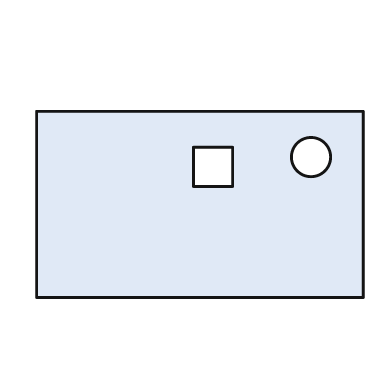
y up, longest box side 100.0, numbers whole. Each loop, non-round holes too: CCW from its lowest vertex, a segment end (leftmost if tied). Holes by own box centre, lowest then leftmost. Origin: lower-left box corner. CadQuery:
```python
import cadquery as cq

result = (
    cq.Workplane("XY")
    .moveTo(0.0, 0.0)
    .lineTo(100.0, 0.0)
    .lineTo(100.0, 57.0)
    .lineTo(0.0, 57.0)
    .close()
    .moveTo(48.0, 34.0)
    .lineTo(60.0, 34.0)
    .lineTo(60.0, 46.0)
    .lineTo(48.0, 46.0)
    .close()
    .moveTo(84.0, 43.0)
    .circle(6.0)
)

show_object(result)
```